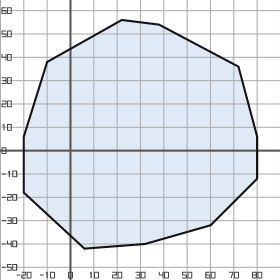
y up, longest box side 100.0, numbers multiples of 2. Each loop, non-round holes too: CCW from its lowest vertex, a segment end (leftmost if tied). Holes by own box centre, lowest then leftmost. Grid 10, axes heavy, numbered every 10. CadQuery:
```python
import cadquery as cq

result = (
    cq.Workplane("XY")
    .moveTo(6.0, -42.0)
    .lineTo(32.0, -40.0)
    .lineTo(60.0, -32.0)
    .lineTo(80.0, -12.0)
    .lineTo(80.0, 6.0)
    .lineTo(72.0, 36.0)
    .lineTo(38.0, 54.0)
    .lineTo(22.0, 56.0)
    .lineTo(-10.0, 38.0)
    .lineTo(-20.0, 6.0)
    .lineTo(-20.0, -18.0)
    .close()
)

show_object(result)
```